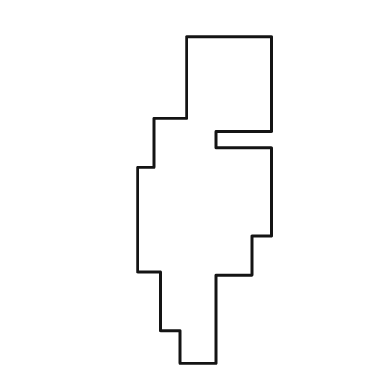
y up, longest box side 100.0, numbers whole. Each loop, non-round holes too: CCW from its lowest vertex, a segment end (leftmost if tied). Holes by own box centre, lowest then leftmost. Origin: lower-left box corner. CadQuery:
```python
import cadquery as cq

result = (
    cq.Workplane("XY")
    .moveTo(13.0, 0.0)
    .lineTo(24.0, 0.0)
    .lineTo(24.0, 27.0)
    .lineTo(35.0, 27.0)
    .lineTo(35.0, 39.0)
    .lineTo(41.0, 39.0)
    .lineTo(41.0, 66.0)
    .lineTo(24.0, 66.0)
    .lineTo(24.0, 71.0)
    .lineTo(41.0, 71.0)
    .lineTo(41.0, 100.0)
    .lineTo(15.0, 100.0)
    .lineTo(15.0, 75.0)
    .lineTo(5.0, 75.0)
    .lineTo(5.0, 60.0)
    .lineTo(0.0, 60.0)
    .lineTo(0.0, 28.0)
    .lineTo(7.0, 28.0)
    .lineTo(7.0, 10.0)
    .lineTo(13.0, 10.0)
    .close()
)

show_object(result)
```